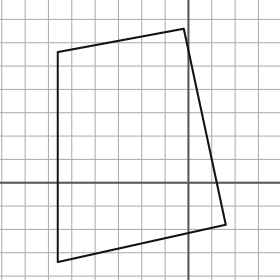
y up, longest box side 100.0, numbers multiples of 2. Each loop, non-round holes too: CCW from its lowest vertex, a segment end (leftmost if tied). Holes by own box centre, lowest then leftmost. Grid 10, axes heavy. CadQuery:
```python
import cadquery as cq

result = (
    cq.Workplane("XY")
    .moveTo(-56.0, -34.0)
    .lineTo(16.0, -18.0)
    .lineTo(-2.0, 66.0)
    .lineTo(-56.0, 56.0)
    .close()
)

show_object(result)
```